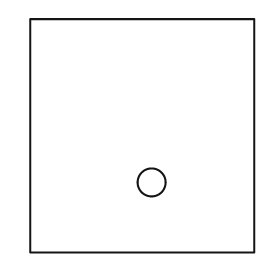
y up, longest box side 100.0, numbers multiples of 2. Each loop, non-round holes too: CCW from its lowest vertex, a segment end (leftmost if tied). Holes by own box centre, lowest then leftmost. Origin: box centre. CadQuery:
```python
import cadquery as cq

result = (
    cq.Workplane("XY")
    .moveTo(-48.0, -50.0)
    .lineTo(48.0, -50.0)
    .lineTo(48.0, 50.0)
    .lineTo(-48.0, 50.0)
    .close()
    .moveTo(4.0, -20.0)
    .circle(6.0)
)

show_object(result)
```